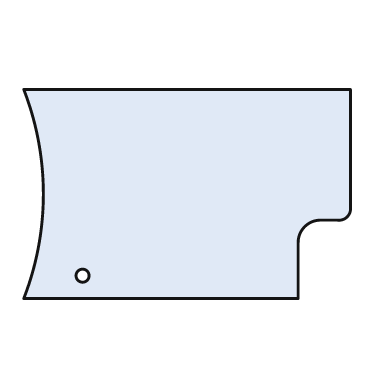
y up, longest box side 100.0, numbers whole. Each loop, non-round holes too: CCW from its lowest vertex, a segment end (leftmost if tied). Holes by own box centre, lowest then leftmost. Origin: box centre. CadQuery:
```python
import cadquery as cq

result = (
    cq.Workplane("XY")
    .moveTo(-50.0, -32.0)
    .lineTo(34.0, -32.0)
    .lineTo(34.0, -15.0)
    .threePointArc((36.0, -10.0), (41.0, -8.0))
    .lineTo(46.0, -8.0)
    .threePointArc((49.0, -7.0), (50.0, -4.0))
    .lineTo(50.0, 32.0)
    .lineTo(-50.0, 32.0)
    .threePointArc((-44.0, 0.0), (-50.0, -32.0))
    .close()
    .moveTo(-32.0, -25.0)
    .circle(2.0)
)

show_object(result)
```